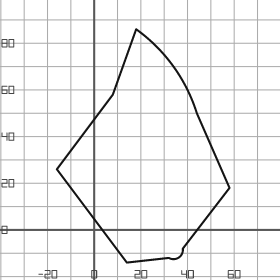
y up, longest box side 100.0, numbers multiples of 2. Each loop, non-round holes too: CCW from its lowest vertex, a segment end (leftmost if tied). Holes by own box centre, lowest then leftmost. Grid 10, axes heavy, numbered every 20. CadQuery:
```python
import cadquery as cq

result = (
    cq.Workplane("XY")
    .moveTo(14.0, -14.0)
    .lineTo(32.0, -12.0)
    .threePointArc((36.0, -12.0), (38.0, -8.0))
    .lineTo(58.0, 18.0)
    .lineTo(44.0, 50.0)
    .threePointArc((34.0, 70.0), (18.0, 86.0))
    .lineTo(8.0, 58.0)
    .lineTo(-16.0, 26.0)
    .close()
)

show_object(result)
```